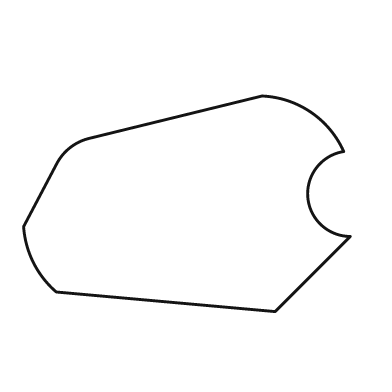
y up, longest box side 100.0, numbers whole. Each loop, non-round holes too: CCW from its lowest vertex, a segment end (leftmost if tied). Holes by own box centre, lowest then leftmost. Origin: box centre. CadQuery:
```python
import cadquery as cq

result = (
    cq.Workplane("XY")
    .moveTo(27.0, -33.0)
    .lineTo(50.0, -10.0)
    .threePointArc((37.0, 2.0), (48.0, 16.0))
    .threePointArc((38.0, 28.0), (23.0, 33.0))
    .lineTo(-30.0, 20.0)
    .threePointArc((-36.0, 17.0), (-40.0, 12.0))
    .lineTo(-50.0, -7.0)
    .threePointArc((-47.0, -18.0), (-40.0, -27.0))
    .close()
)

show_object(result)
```